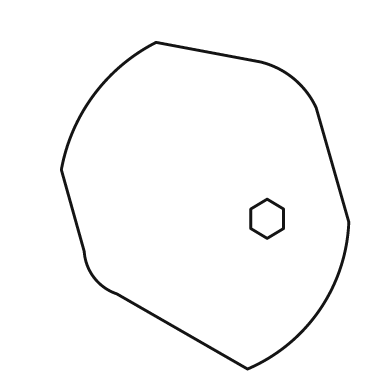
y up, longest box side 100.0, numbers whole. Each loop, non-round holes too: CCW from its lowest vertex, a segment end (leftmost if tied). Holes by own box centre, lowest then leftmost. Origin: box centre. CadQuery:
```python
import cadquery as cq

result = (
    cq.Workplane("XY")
    .moveTo(13.0, -50.0)
    .threePointArc((35.0, -32.0), (44.0, -5.0))
    .lineTo(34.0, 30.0)
    .threePointArc((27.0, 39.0), (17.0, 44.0))
    .lineTo(-15.0, 50.0)
    .threePointArc((-34.0, 34.0), (-44.0, 11.0))
    .lineTo(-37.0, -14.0)
    .threePointArc((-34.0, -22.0), (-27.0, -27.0))
    .close()
    .moveTo(19.0, -10.0)
    .lineTo(24.0, -7.0)
    .lineTo(24.0, -1.0)
    .lineTo(19.0, 2.0)
    .lineTo(14.0, -1.0)
    .lineTo(14.0, -7.0)
    .close()
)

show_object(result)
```